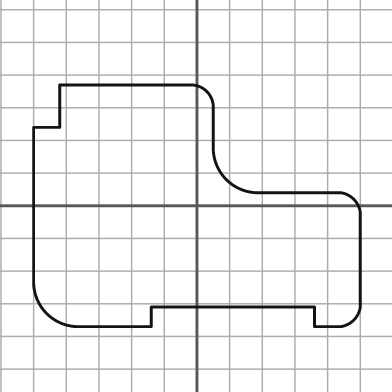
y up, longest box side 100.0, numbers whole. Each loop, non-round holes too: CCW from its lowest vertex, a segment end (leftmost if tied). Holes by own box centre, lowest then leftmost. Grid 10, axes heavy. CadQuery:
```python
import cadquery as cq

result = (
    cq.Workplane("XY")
    .moveTo(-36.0, -37.0)
    .lineTo(-14.0, -37.0)
    .lineTo(-14.0, -31.0)
    .lineTo(36.0, -31.0)
    .lineTo(36.0, -37.0)
    .lineTo(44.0, -37.0)
    .threePointArc((48.0, -35.0), (50.0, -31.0))
    .lineTo(50.0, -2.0)
    .threePointArc((48.0, 2.0), (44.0, 4.0))
    .lineTo(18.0, 4.0)
    .threePointArc((9.0, 8.0), (5.0, 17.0))
    .lineTo(5.0, 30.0)
    .threePointArc((3.0, 35.0), (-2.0, 37.0))
    .lineTo(-42.0, 37.0)
    .lineTo(-42.0, 24.0)
    .lineTo(-50.0, 24.0)
    .lineTo(-50.0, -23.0)
    .threePointArc((-46.0, -33.0), (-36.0, -37.0))
    .close()
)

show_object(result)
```